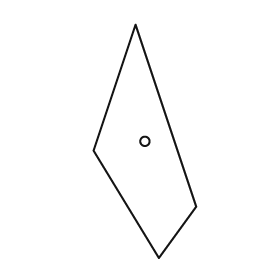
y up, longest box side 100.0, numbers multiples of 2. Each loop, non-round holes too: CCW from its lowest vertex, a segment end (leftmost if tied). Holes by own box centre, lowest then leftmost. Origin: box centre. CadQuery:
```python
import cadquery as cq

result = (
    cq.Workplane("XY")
    .moveTo(6.0, -50.0)
    .lineTo(22.0, -28.0)
    .lineTo(-4.0, 50.0)
    .lineTo(-22.0, -4.0)
    .close()
    .moveTo(0.0, 0.0)
    .circle(2.0)
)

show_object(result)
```